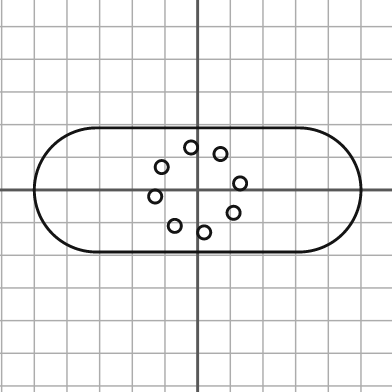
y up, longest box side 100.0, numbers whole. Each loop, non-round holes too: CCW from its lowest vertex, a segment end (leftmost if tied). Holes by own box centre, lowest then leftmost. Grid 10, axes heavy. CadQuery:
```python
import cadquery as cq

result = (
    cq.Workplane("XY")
    .moveTo(-31.0, -19.0)
    .lineTo(31.0, -19.0)
    .threePointArc((50.0, 0.0), (31.0, 19.0))
    .lineTo(-31.0, 19.0)
    .threePointArc((-50.0, 0.0), (-31.0, -19.0))
    .close()
    .moveTo(2.0, -13.0)
    .circle(2.0)
    .moveTo(-7.0, -11.0)
    .circle(2.0)
    .moveTo(11.0, -7.0)
    .circle(2.0)
    .moveTo(-13.0, -2.0)
    .circle(2.0)
    .moveTo(13.0, 2.0)
    .circle(2.0)
    .moveTo(-11.0, 7.0)
    .circle(2.0)
    .moveTo(7.0, 11.0)
    .circle(2.0)
    .moveTo(-2.0, 13.0)
    .circle(2.0)
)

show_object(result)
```